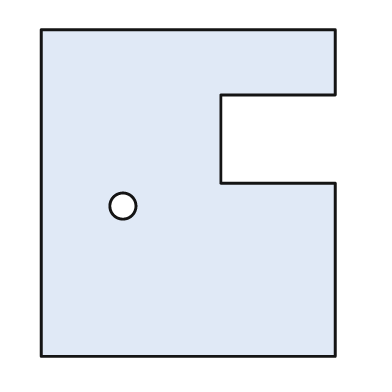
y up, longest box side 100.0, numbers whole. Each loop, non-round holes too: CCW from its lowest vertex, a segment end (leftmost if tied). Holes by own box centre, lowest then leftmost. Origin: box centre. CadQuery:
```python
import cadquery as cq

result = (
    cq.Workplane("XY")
    .moveTo(-45.0, -50.0)
    .lineTo(45.0, -50.0)
    .lineTo(45.0, 3.0)
    .lineTo(10.0, 3.0)
    .lineTo(10.0, 30.0)
    .lineTo(45.0, 30.0)
    .lineTo(45.0, 50.0)
    .lineTo(-45.0, 50.0)
    .close()
    .moveTo(-20.0, -4.0)
    .circle(4.0)
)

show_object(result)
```